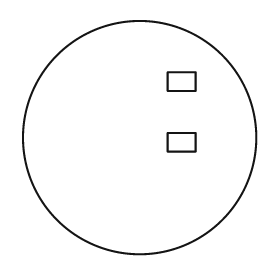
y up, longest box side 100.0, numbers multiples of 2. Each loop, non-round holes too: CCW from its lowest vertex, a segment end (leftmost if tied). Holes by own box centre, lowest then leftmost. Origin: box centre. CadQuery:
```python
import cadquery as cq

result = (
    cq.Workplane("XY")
    .moveTo(0.0, 0.0)
    .circle(50.0)
    .moveTo(12.0, -6.0)
    .lineTo(24.0, -6.0)
    .lineTo(24.0, 2.0)
    .lineTo(12.0, 2.0)
    .close()
    .moveTo(12.0, 20.0)
    .lineTo(24.0, 20.0)
    .lineTo(24.0, 28.0)
    .lineTo(12.0, 28.0)
    .close()
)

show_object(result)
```